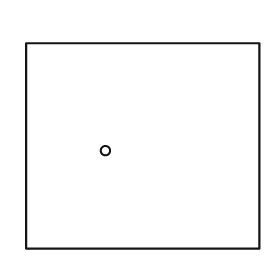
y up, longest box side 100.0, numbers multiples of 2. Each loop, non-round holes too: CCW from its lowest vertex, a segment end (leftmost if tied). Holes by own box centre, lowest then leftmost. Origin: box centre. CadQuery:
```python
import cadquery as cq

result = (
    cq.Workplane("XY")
    .moveTo(-50.0, -44.0)
    .lineTo(50.0, -44.0)
    .lineTo(50.0, 44.0)
    .lineTo(-50.0, 44.0)
    .close()
    .moveTo(-16.0, -2.0)
    .circle(2.0)
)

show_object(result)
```